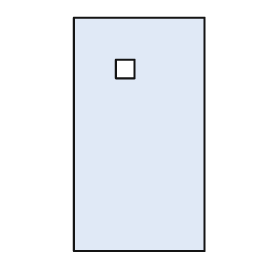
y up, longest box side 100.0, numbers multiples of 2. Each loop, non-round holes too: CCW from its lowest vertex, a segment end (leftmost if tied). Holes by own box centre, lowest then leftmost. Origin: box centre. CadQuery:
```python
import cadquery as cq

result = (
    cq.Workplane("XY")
    .moveTo(-28.0, -50.0)
    .lineTo(28.0, -50.0)
    .lineTo(28.0, 50.0)
    .lineTo(-28.0, 50.0)
    .close()
    .moveTo(-10.0, 24.0)
    .lineTo(-2.0, 24.0)
    .lineTo(-2.0, 32.0)
    .lineTo(-10.0, 32.0)
    .close()
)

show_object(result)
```